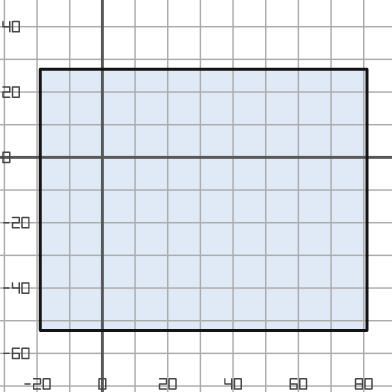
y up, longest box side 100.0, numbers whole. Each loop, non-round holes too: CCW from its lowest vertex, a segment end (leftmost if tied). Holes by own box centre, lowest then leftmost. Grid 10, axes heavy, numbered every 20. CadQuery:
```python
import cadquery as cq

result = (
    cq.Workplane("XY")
    .moveTo(-19.0, -53.0)
    .lineTo(81.0, -53.0)
    .lineTo(81.0, 27.0)
    .lineTo(-19.0, 27.0)
    .close()
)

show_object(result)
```